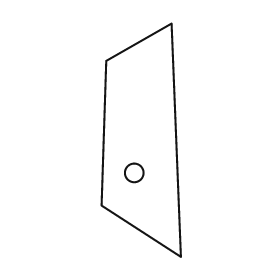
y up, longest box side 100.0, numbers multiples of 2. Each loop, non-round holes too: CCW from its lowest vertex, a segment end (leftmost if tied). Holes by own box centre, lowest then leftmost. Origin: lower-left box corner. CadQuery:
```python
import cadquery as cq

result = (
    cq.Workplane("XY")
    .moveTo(34.0, 0.0)
    .lineTo(30.0, 100.0)
    .lineTo(2.0, 84.0)
    .lineTo(0.0, 22.0)
    .close()
    .moveTo(14.0, 36.0)
    .circle(4.0)
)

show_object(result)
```